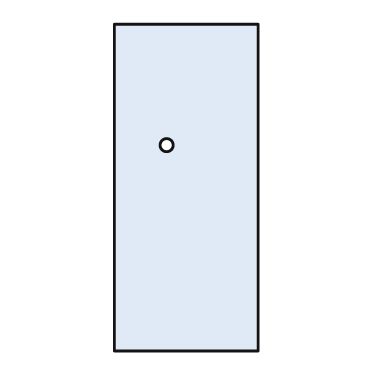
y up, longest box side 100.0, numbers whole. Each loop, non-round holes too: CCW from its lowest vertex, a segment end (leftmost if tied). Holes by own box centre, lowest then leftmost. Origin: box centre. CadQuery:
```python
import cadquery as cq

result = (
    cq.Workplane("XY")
    .moveTo(-22.0, -50.0)
    .lineTo(22.0, -50.0)
    .lineTo(22.0, 50.0)
    .lineTo(-22.0, 50.0)
    .close()
    .moveTo(-6.0, 13.0)
    .circle(2.0)
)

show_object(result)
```